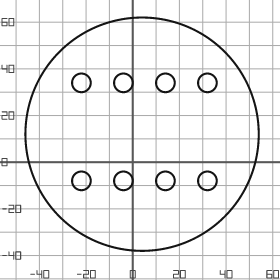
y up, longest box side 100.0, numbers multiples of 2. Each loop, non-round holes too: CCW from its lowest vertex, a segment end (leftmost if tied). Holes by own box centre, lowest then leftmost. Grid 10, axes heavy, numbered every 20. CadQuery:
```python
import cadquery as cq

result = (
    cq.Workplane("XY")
    .moveTo(4.0, 12.0)
    .circle(50.0)
    .moveTo(-22.0, -8.0)
    .circle(4.0)
    .moveTo(-4.0, -8.0)
    .circle(4.0)
    .moveTo(14.0, -8.0)
    .circle(4.0)
    .moveTo(32.0, -8.0)
    .circle(4.0)
    .moveTo(-22.0, 34.0)
    .circle(4.0)
    .moveTo(-4.0, 34.0)
    .circle(4.0)
    .moveTo(14.0, 34.0)
    .circle(4.0)
    .moveTo(32.0, 34.0)
    .circle(4.0)
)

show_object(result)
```